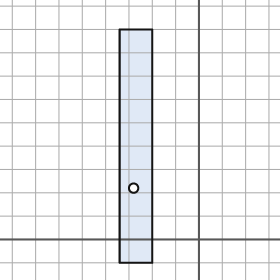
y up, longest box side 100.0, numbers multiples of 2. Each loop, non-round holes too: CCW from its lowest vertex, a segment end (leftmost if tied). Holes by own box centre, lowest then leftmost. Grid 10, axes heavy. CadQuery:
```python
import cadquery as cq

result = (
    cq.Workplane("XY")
    .moveTo(-34.0, -10.0)
    .lineTo(-20.0, -10.0)
    .lineTo(-20.0, 90.0)
    .lineTo(-34.0, 90.0)
    .close()
    .moveTo(-28.0, 22.0)
    .circle(2.0)
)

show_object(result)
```